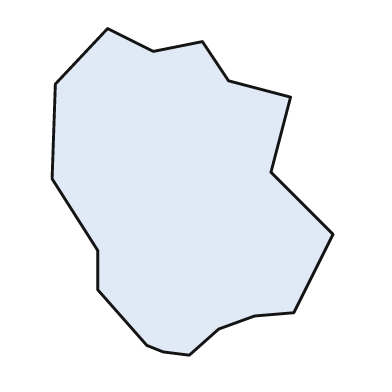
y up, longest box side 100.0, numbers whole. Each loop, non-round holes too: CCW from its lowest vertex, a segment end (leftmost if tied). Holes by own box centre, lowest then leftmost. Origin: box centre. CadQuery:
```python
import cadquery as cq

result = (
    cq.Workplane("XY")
    .moveTo(-1.0, -50.0)
    .lineTo(8.0, -42.0)
    .lineTo(19.0, -38.0)
    .lineTo(31.0, -37.0)
    .lineTo(43.0, -13.0)
    .lineTo(24.0, 6.0)
    .lineTo(30.0, 29.0)
    .lineTo(11.0, 34.0)
    .lineTo(3.0, 46.0)
    .lineTo(-12.0, 43.0)
    .lineTo(-26.0, 50.0)
    .lineTo(-42.0, 33.0)
    .lineTo(-43.0, 4.0)
    .lineTo(-29.0, -18.0)
    .lineTo(-29.0, -30.0)
    .lineTo(-14.0, -47.0)
    .lineTo(-9.0, -49.0)
    .close()
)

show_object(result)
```